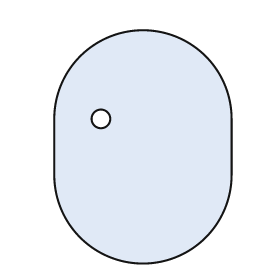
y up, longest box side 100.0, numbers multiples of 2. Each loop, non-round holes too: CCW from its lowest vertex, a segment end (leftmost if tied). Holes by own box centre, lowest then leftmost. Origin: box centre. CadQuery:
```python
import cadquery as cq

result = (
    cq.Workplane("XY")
    .moveTo(-38.0, -12.0)
    .threePointArc((0.0, -50.0), (38.0, -12.0))
    .lineTo(38.0, 12.0)
    .threePointArc((0.0, 50.0), (-38.0, 12.0))
    .close()
    .moveTo(-18.0, 12.0)
    .circle(4.0)
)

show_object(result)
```